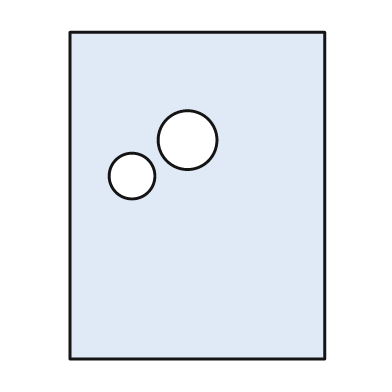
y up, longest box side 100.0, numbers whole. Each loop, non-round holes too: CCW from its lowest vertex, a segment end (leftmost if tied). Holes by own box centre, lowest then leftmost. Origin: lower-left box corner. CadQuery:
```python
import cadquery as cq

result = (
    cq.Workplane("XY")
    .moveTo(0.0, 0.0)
    .lineTo(78.0, 0.0)
    .lineTo(78.0, 100.0)
    .lineTo(0.0, 100.0)
    .close()
    .moveTo(19.0, 56.0)
    .circle(7.0)
    .moveTo(36.0, 67.0)
    .circle(9.0)
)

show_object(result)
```